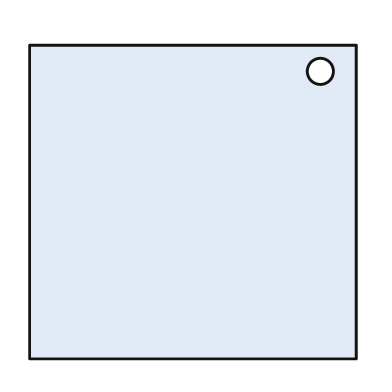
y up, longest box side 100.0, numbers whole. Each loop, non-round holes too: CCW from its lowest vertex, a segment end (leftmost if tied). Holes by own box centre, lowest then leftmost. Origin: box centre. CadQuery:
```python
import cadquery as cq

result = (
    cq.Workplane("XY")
    .moveTo(-50.0, -48.0)
    .lineTo(50.0, -48.0)
    .lineTo(50.0, 48.0)
    .lineTo(-50.0, 48.0)
    .close()
    .moveTo(39.0, 40.0)
    .circle(4.0)
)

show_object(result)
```